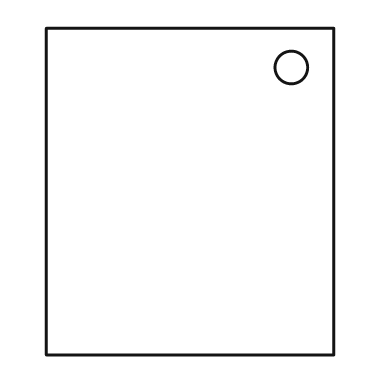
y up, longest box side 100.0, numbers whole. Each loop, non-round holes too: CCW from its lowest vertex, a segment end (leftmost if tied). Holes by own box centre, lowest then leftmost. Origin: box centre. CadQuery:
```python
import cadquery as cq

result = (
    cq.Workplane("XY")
    .moveTo(-44.0, -50.0)
    .lineTo(44.0, -50.0)
    .lineTo(44.0, 50.0)
    .lineTo(-44.0, 50.0)
    .close()
    .moveTo(31.0, 38.0)
    .circle(5.0)
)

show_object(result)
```